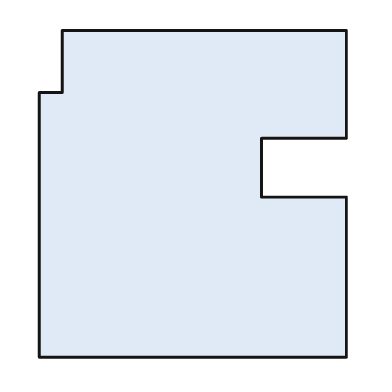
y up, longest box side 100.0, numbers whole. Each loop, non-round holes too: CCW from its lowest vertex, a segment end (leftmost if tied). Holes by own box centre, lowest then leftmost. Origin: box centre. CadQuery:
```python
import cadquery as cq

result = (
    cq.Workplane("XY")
    .moveTo(-47.0, -50.0)
    .lineTo(47.0, -50.0)
    .lineTo(47.0, -1.0)
    .lineTo(21.0, -1.0)
    .lineTo(21.0, 17.0)
    .lineTo(47.0, 17.0)
    .lineTo(47.0, 50.0)
    .lineTo(-40.0, 50.0)
    .lineTo(-40.0, 31.0)
    .lineTo(-47.0, 31.0)
    .close()
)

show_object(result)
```